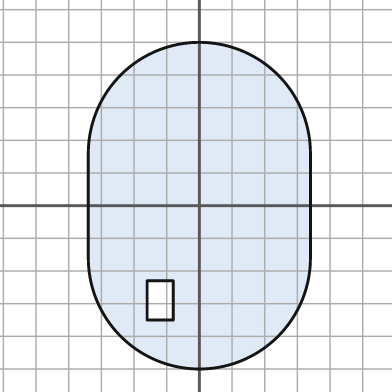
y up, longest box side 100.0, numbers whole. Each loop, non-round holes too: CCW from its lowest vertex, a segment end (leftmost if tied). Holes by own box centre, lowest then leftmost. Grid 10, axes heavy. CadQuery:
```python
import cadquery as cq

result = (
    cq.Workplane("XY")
    .moveTo(-34.0, -16.0)
    .threePointArc((0.0, -50.0), (34.0, -16.0))
    .lineTo(34.0, 16.0)
    .threePointArc((0.0, 50.0), (-34.0, 16.0))
    .close()
    .moveTo(-16.0, -35.0)
    .lineTo(-8.0, -35.0)
    .lineTo(-8.0, -23.0)
    .lineTo(-16.0, -23.0)
    .close()
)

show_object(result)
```